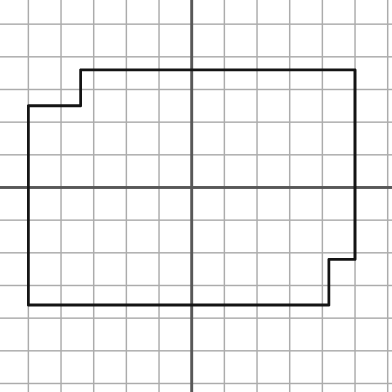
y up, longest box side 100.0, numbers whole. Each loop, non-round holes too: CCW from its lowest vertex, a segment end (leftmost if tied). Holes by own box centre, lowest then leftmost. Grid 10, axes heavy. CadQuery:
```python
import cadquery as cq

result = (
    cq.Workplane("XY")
    .moveTo(-50.0, -36.0)
    .lineTo(42.0, -36.0)
    .lineTo(42.0, -22.0)
    .lineTo(50.0, -22.0)
    .lineTo(50.0, 36.0)
    .lineTo(-34.0, 36.0)
    .lineTo(-34.0, 25.0)
    .lineTo(-50.0, 25.0)
    .close()
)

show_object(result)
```